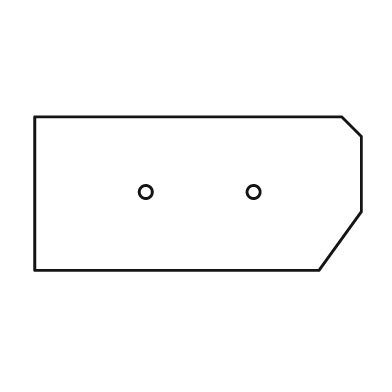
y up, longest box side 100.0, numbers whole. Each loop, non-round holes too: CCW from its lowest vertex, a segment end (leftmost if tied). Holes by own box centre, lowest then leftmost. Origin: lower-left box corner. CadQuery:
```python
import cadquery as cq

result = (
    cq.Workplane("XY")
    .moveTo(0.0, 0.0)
    .lineTo(87.0, 0.0)
    .lineTo(100.0, 18.0)
    .lineTo(100.0, 41.0)
    .lineTo(94.0, 47.0)
    .lineTo(0.0, 47.0)
    .close()
    .moveTo(34.0, 24.0)
    .circle(2.0)
    .moveTo(67.0, 24.0)
    .circle(2.0)
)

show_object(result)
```